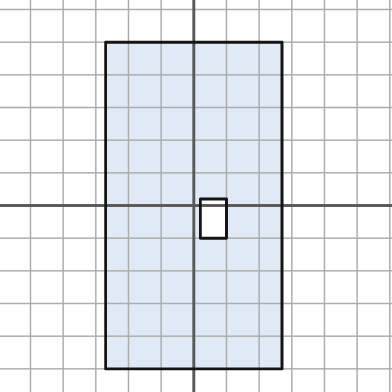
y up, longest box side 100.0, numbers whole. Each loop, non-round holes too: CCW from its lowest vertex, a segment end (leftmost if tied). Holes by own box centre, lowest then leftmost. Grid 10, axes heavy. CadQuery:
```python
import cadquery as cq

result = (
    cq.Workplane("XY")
    .moveTo(-27.0, -50.0)
    .lineTo(27.0, -50.0)
    .lineTo(27.0, 50.0)
    .lineTo(-27.0, 50.0)
    .close()
    .moveTo(2.0, -10.0)
    .lineTo(10.0, -10.0)
    .lineTo(10.0, 2.0)
    .lineTo(2.0, 2.0)
    .close()
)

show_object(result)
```